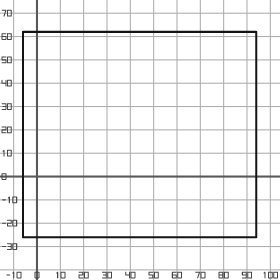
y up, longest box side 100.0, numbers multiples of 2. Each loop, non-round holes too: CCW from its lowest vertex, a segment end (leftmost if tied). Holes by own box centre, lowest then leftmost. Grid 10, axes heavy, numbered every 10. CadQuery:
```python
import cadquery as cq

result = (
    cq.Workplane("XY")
    .moveTo(-6.0, -26.0)
    .lineTo(94.0, -26.0)
    .lineTo(94.0, 62.0)
    .lineTo(-6.0, 62.0)
    .close()
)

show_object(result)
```